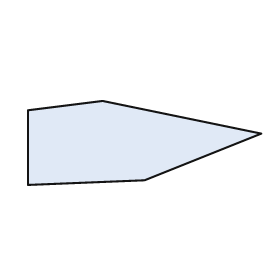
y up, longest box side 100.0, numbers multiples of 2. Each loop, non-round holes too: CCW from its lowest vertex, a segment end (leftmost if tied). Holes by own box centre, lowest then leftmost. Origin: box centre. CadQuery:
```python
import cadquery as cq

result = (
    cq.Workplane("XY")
    .moveTo(-50.0, -18.0)
    .lineTo(0.0, -16.0)
    .lineTo(50.0, 4.0)
    .lineTo(-18.0, 18.0)
    .lineTo(-50.0, 14.0)
    .close()
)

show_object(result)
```